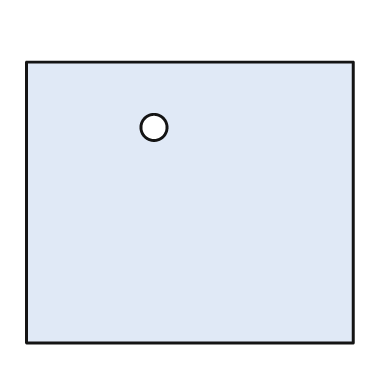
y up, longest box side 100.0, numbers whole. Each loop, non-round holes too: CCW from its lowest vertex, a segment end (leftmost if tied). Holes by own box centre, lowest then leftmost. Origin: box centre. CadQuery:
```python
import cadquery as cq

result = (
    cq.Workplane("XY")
    .moveTo(-50.0, -43.0)
    .lineTo(50.0, -43.0)
    .lineTo(50.0, 43.0)
    .lineTo(-50.0, 43.0)
    .close()
    .moveTo(-11.0, 23.0)
    .circle(4.0)
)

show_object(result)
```